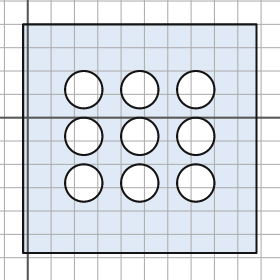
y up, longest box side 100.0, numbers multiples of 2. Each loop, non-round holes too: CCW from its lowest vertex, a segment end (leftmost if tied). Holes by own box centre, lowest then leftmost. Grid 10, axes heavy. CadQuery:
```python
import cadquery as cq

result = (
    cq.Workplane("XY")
    .moveTo(-2.0, -58.0)
    .lineTo(98.0, -58.0)
    .lineTo(98.0, 40.0)
    .lineTo(-2.0, 40.0)
    .close()
    .moveTo(24.0, -28.0)
    .circle(8.0)
    .moveTo(48.0, -28.0)
    .circle(8.0)
    .moveTo(72.0, -28.0)
    .circle(8.0)
    .moveTo(24.0, -8.0)
    .circle(8.0)
    .moveTo(48.0, -8.0)
    .circle(8.0)
    .moveTo(72.0, -8.0)
    .circle(8.0)
    .moveTo(24.0, 12.0)
    .circle(8.0)
    .moveTo(48.0, 12.0)
    .circle(8.0)
    .moveTo(72.0, 12.0)
    .circle(8.0)
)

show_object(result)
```